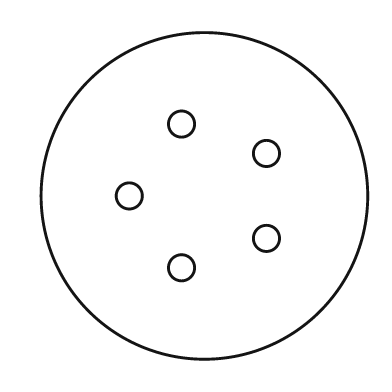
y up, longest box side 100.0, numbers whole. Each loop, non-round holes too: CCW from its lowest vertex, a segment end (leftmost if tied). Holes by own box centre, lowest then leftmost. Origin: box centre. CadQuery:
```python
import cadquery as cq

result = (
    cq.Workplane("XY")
    .moveTo(0.0, 0.0)
    .circle(50.0)
    .moveTo(-7.0, -22.0)
    .circle(4.0)
    .moveTo(19.0, -13.0)
    .circle(4.0)
    .moveTo(-23.0, 0.0)
    .circle(4.0)
    .moveTo(19.0, 13.0)
    .circle(4.0)
    .moveTo(-7.0, 22.0)
    .circle(4.0)
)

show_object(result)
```